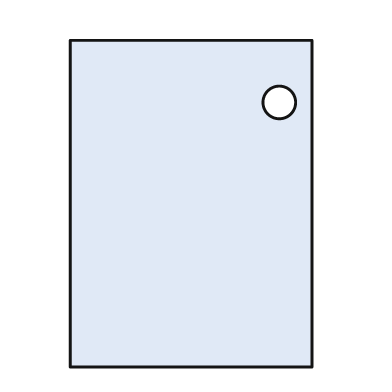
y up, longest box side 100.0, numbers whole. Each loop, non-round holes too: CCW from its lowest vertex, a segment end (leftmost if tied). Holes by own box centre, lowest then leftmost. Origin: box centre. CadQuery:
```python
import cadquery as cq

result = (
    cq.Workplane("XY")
    .moveTo(-37.0, -50.0)
    .lineTo(37.0, -50.0)
    .lineTo(37.0, 50.0)
    .lineTo(-37.0, 50.0)
    .close()
    .moveTo(27.0, 31.0)
    .circle(5.0)
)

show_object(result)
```